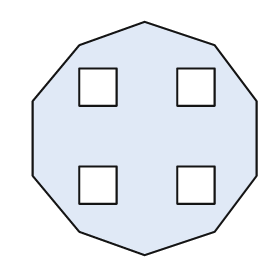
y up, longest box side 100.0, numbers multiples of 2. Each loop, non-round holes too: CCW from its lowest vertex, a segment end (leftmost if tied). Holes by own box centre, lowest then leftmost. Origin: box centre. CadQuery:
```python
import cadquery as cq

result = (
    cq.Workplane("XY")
    .moveTo(0.0, -50.0)
    .lineTo(30.0, -40.0)
    .lineTo(48.0, -16.0)
    .lineTo(48.0, 16.0)
    .lineTo(30.0, 40.0)
    .lineTo(0.0, 50.0)
    .lineTo(-28.0, 40.0)
    .lineTo(-48.0, 16.0)
    .lineTo(-48.0, -16.0)
    .lineTo(-28.0, -40.0)
    .close()
    .moveTo(-28.0, -28.0)
    .lineTo(-12.0, -28.0)
    .lineTo(-12.0, -12.0)
    .lineTo(-28.0, -12.0)
    .close()
    .moveTo(14.0, -28.0)
    .lineTo(30.0, -28.0)
    .lineTo(30.0, -12.0)
    .lineTo(14.0, -12.0)
    .close()
    .moveTo(-28.0, 14.0)
    .lineTo(-12.0, 14.0)
    .lineTo(-12.0, 30.0)
    .lineTo(-28.0, 30.0)
    .close()
    .moveTo(14.0, 14.0)
    .lineTo(30.0, 14.0)
    .lineTo(30.0, 30.0)
    .lineTo(14.0, 30.0)
    .close()
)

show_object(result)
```